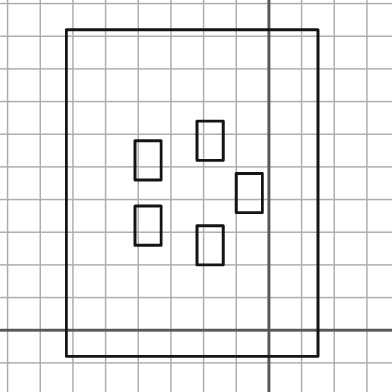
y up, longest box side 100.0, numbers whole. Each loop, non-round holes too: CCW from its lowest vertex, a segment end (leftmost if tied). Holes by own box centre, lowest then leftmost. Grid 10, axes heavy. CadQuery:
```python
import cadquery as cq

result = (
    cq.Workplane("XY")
    .moveTo(-62.0, -8.0)
    .lineTo(15.0, -8.0)
    .lineTo(15.0, 92.0)
    .lineTo(-62.0, 92.0)
    .close()
    .moveTo(-22.0, 20.0)
    .lineTo(-14.0, 20.0)
    .lineTo(-14.0, 32.0)
    .lineTo(-22.0, 32.0)
    .close()
    .moveTo(-41.0, 26.0)
    .lineTo(-33.0, 26.0)
    .lineTo(-33.0, 38.0)
    .lineTo(-41.0, 38.0)
    .close()
    .moveTo(-10.0, 36.0)
    .lineTo(-2.0, 36.0)
    .lineTo(-2.0, 48.0)
    .lineTo(-10.0, 48.0)
    .close()
    .moveTo(-41.0, 46.0)
    .lineTo(-33.0, 46.0)
    .lineTo(-33.0, 58.0)
    .lineTo(-41.0, 58.0)
    .close()
    .moveTo(-22.0, 52.0)
    .lineTo(-14.0, 52.0)
    .lineTo(-14.0, 64.0)
    .lineTo(-22.0, 64.0)
    .close()
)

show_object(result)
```